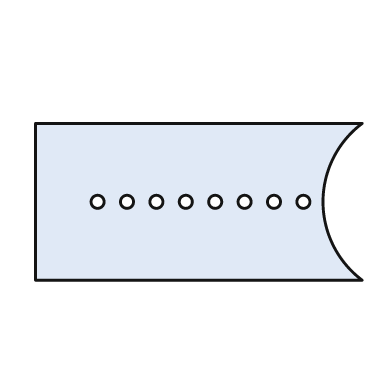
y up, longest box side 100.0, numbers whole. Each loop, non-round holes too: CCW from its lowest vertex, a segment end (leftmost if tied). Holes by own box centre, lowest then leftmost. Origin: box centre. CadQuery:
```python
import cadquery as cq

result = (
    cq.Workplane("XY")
    .moveTo(-50.0, -24.0)
    .lineTo(50.0, -24.0)
    .threePointArc((38.0, 0.0), (50.0, 24.0))
    .lineTo(-50.0, 24.0)
    .close()
    .moveTo(-31.0, 0.0)
    .circle(2.0)
    .moveTo(-22.0, 0.0)
    .circle(2.0)
    .moveTo(-13.0, 0.0)
    .circle(2.0)
    .moveTo(-4.0, 0.0)
    .circle(2.0)
    .moveTo(5.0, 0.0)
    .circle(2.0)
    .moveTo(14.0, 0.0)
    .circle(2.0)
    .moveTo(23.0, 0.0)
    .circle(2.0)
    .moveTo(32.0, 0.0)
    .circle(2.0)
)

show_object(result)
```